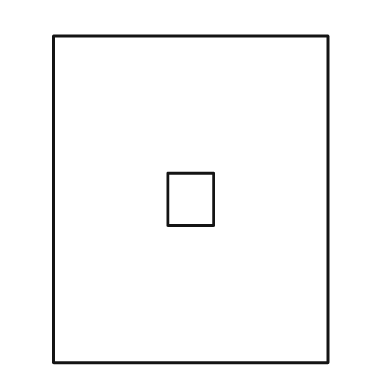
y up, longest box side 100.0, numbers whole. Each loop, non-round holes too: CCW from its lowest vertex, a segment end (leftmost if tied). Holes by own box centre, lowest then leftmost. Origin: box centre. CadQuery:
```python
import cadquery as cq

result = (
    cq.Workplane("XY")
    .moveTo(-42.0, -50.0)
    .lineTo(42.0, -50.0)
    .lineTo(42.0, 50.0)
    .lineTo(-42.0, 50.0)
    .close()
    .moveTo(-7.0, -8.0)
    .lineTo(7.0, -8.0)
    .lineTo(7.0, 8.0)
    .lineTo(-7.0, 8.0)
    .close()
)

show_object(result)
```